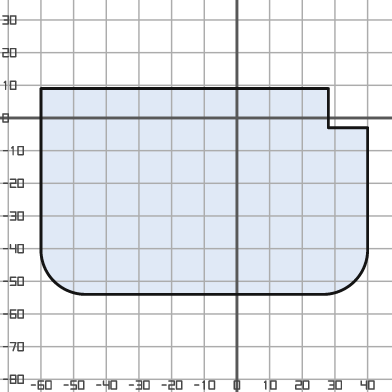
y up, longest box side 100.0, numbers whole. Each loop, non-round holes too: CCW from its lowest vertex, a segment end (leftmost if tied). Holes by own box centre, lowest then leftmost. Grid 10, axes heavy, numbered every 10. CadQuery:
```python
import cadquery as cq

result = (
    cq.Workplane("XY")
    .moveTo(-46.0, -54.0)
    .lineTo(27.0, -54.0)
    .threePointArc((36.0, -50.0), (40.0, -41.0))
    .lineTo(40.0, -3.0)
    .lineTo(28.0, -3.0)
    .lineTo(28.0, 9.0)
    .lineTo(-60.0, 9.0)
    .lineTo(-60.0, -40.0)
    .threePointArc((-56.0, -50.0), (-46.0, -54.0))
    .close()
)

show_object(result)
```